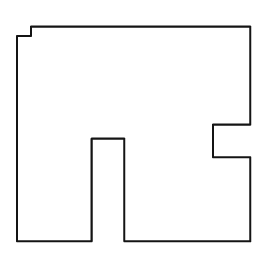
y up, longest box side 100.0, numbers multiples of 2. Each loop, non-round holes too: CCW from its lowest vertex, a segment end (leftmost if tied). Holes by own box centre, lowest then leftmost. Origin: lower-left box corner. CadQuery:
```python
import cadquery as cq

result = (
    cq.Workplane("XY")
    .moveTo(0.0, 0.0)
    .lineTo(32.0, 0.0)
    .lineTo(32.0, 44.0)
    .lineTo(46.0, 44.0)
    .lineTo(46.0, 0.0)
    .lineTo(100.0, 0.0)
    .lineTo(100.0, 36.0)
    .lineTo(84.0, 36.0)
    .lineTo(84.0, 50.0)
    .lineTo(100.0, 50.0)
    .lineTo(100.0, 92.0)
    .lineTo(6.0, 92.0)
    .lineTo(6.0, 88.0)
    .lineTo(0.0, 88.0)
    .close()
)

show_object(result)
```